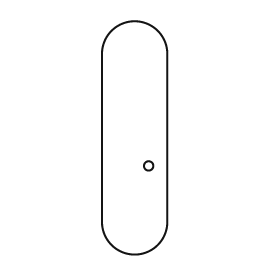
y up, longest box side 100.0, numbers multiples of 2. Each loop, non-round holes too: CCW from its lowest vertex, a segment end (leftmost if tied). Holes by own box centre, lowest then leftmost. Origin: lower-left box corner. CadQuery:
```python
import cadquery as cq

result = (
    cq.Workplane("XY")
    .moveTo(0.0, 14.0)
    .threePointArc((14.0, 0.0), (28.0, 14.0))
    .lineTo(28.0, 86.0)
    .threePointArc((14.0, 100.0), (0.0, 86.0))
    .close()
    .moveTo(20.0, 38.0)
    .circle(2.0)
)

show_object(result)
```